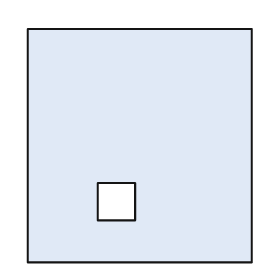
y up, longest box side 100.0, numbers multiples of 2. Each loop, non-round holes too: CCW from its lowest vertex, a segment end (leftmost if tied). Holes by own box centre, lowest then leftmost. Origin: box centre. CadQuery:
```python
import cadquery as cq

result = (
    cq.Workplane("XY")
    .moveTo(-48.0, -50.0)
    .lineTo(48.0, -50.0)
    .lineTo(48.0, 50.0)
    .lineTo(-48.0, 50.0)
    .close()
    .moveTo(-18.0, -32.0)
    .lineTo(-2.0, -32.0)
    .lineTo(-2.0, -16.0)
    .lineTo(-18.0, -16.0)
    .close()
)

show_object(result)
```